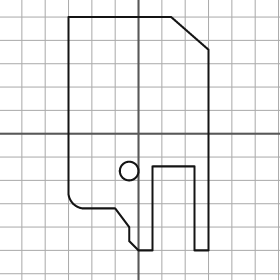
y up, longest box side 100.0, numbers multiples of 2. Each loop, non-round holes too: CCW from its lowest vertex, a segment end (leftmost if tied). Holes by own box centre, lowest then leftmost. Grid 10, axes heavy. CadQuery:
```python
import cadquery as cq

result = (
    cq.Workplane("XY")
    .moveTo(0.0, -50.0)
    .lineTo(6.0, -50.0)
    .lineTo(6.0, -14.0)
    .lineTo(24.0, -14.0)
    .lineTo(24.0, -50.0)
    .lineTo(30.0, -50.0)
    .lineTo(30.0, 36.0)
    .lineTo(14.0, 50.0)
    .lineTo(-30.0, 50.0)
    .lineTo(-30.0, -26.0)
    .threePointArc((-28.0, -30.0), (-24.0, -32.0))
    .lineTo(-10.0, -32.0)
    .lineTo(-4.0, -40.0)
    .lineTo(-4.0, -46.0)
    .close()
    .moveTo(-4.0, -16.0)
    .circle(4.0)
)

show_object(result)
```